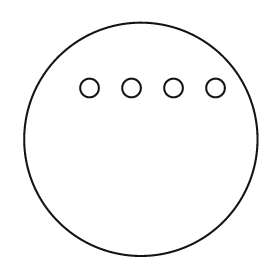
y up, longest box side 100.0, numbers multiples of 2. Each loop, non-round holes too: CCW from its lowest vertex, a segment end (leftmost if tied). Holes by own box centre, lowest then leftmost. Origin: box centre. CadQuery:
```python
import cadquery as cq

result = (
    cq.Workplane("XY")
    .moveTo(0.0, 0.0)
    .circle(50.0)
    .moveTo(-22.0, 22.0)
    .circle(4.0)
    .moveTo(-4.0, 22.0)
    .circle(4.0)
    .moveTo(14.0, 22.0)
    .circle(4.0)
    .moveTo(32.0, 22.0)
    .circle(4.0)
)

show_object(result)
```